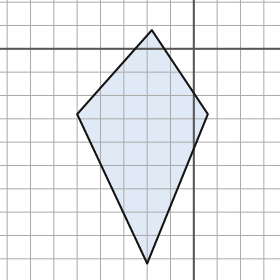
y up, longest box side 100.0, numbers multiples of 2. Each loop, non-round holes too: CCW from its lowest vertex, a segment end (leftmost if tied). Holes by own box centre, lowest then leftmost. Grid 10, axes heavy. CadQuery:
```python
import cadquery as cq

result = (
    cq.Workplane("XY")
    .moveTo(-20.0, -92.0)
    .lineTo(6.0, -28.0)
    .lineTo(-18.0, 8.0)
    .lineTo(-50.0, -28.0)
    .close()
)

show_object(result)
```